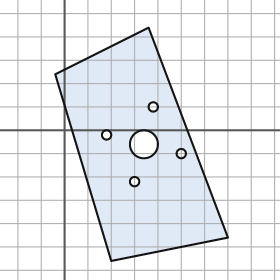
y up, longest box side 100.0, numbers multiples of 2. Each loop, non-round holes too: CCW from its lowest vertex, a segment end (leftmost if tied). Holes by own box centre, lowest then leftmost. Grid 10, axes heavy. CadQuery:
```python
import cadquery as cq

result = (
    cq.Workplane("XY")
    .moveTo(20.0, -56.0)
    .lineTo(70.0, -46.0)
    .lineTo(36.0, 44.0)
    .lineTo(-4.0, 24.0)
    .close()
    .moveTo(30.0, -22.0)
    .circle(2.0)
    .moveTo(50.0, -10.0)
    .circle(2.0)
    .moveTo(34.0, -6.0)
    .circle(6.0)
    .moveTo(18.0, -2.0)
    .circle(2.0)
    .moveTo(38.0, 10.0)
    .circle(2.0)
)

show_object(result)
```